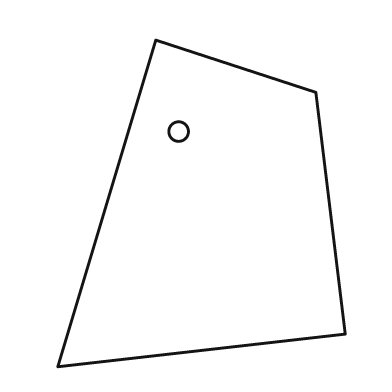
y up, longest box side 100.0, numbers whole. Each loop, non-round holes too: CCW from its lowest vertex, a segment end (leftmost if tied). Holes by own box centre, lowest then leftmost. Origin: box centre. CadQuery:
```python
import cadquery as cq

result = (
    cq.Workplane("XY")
    .moveTo(-44.0, -50.0)
    .lineTo(44.0, -40.0)
    .lineTo(35.0, 34.0)
    .lineTo(-14.0, 50.0)
    .close()
    .moveTo(-7.0, 22.0)
    .circle(3.0)
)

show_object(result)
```